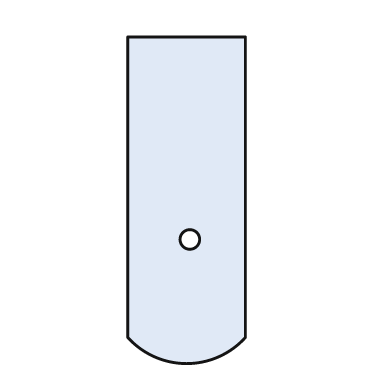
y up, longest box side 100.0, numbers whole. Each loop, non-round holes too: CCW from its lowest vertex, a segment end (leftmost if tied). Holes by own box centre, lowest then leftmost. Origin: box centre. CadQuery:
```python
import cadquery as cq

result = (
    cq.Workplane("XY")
    .moveTo(-18.0, -42.0)
    .threePointArc((0.0, -50.0), (18.0, -42.0))
    .lineTo(18.0, 50.0)
    .lineTo(-18.0, 50.0)
    .close()
    .moveTo(1.0, -12.0)
    .circle(3.0)
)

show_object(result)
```